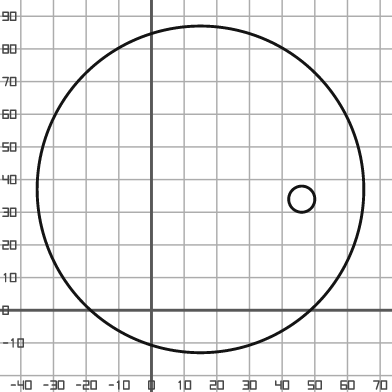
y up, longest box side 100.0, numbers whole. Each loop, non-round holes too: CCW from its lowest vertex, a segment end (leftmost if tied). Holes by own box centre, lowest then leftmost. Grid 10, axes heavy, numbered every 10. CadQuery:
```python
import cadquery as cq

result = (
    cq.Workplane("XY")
    .moveTo(15.0, 37.0)
    .circle(50.0)
    .moveTo(46.0, 34.0)
    .circle(4.0)
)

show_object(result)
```